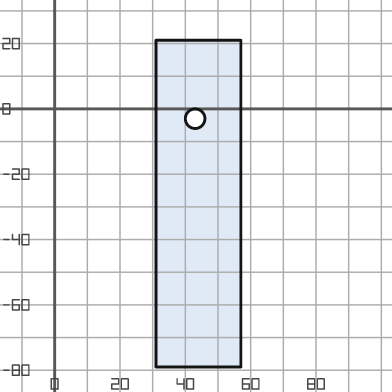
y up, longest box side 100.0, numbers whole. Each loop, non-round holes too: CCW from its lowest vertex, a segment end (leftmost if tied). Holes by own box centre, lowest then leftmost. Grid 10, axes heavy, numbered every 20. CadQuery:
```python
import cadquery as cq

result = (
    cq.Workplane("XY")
    .moveTo(31.0, -79.0)
    .lineTo(57.0, -79.0)
    .lineTo(57.0, 21.0)
    .lineTo(31.0, 21.0)
    .close()
    .moveTo(43.0, -3.0)
    .circle(3.0)
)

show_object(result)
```